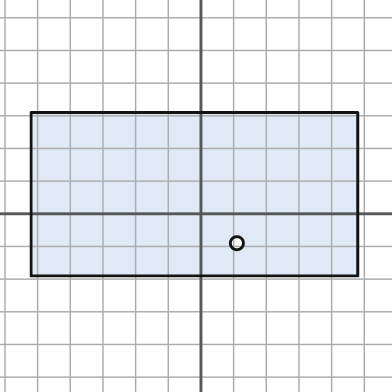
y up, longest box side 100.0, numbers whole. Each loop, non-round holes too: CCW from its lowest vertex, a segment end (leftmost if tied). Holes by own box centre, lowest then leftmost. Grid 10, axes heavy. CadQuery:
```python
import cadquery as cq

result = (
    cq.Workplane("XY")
    .moveTo(-52.0, -19.0)
    .lineTo(48.0, -19.0)
    .lineTo(48.0, 31.0)
    .lineTo(-52.0, 31.0)
    .close()
    .moveTo(11.0, -9.0)
    .circle(2.0)
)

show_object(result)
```